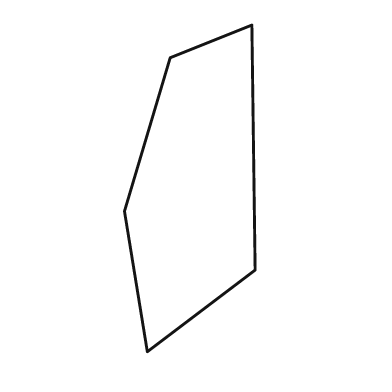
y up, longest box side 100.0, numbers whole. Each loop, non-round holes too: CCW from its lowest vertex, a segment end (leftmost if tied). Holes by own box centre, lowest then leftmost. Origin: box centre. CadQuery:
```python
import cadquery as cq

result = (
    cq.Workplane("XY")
    .moveTo(-13.0, -50.0)
    .lineTo(20.0, -25.0)
    .lineTo(19.0, 50.0)
    .lineTo(-6.0, 40.0)
    .lineTo(-20.0, -7.0)
    .close()
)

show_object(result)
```